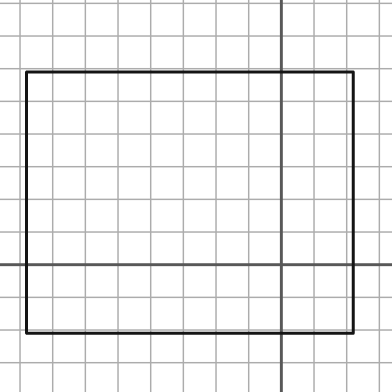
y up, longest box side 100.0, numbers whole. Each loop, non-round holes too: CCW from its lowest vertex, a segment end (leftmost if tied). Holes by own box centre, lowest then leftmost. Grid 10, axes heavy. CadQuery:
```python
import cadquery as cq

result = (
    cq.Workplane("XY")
    .moveTo(-78.0, -21.0)
    .lineTo(22.0, -21.0)
    .lineTo(22.0, 59.0)
    .lineTo(-78.0, 59.0)
    .close()
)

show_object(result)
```